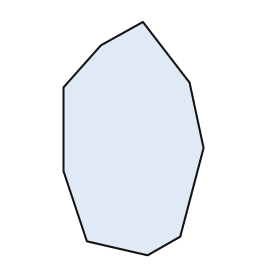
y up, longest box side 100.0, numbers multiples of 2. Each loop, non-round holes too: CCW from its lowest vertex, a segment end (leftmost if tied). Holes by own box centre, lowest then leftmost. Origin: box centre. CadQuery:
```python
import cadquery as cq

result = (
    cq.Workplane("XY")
    .moveTo(6.0, -50.0)
    .lineTo(20.0, -42.0)
    .lineTo(30.0, -4.0)
    .lineTo(24.0, 24.0)
    .lineTo(4.0, 50.0)
    .lineTo(-14.0, 40.0)
    .lineTo(-30.0, 22.0)
    .lineTo(-30.0, -14.0)
    .lineTo(-20.0, -44.0)
    .close()
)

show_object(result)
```